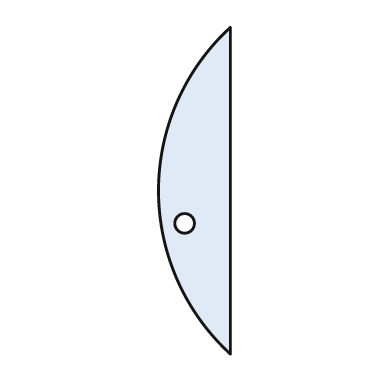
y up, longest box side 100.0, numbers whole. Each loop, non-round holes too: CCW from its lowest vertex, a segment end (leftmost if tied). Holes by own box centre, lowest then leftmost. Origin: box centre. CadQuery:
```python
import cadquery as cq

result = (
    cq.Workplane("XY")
    .moveTo(11.0, -50.0)
    .lineTo(11.0, 50.0)
    .threePointArc((-11.0, 0.0), (11.0, -50.0))
    .close()
    .moveTo(-3.0, -10.0)
    .circle(3.0)
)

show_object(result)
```